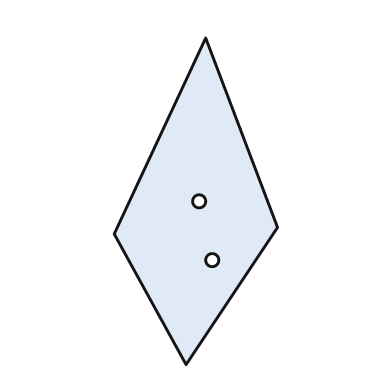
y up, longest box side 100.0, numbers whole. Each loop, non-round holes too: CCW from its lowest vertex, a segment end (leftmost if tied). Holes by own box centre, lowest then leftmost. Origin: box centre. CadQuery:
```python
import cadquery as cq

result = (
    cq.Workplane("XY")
    .moveTo(-3.0, -50.0)
    .lineTo(25.0, -8.0)
    .lineTo(3.0, 50.0)
    .lineTo(-25.0, -10.0)
    .close()
    .moveTo(5.0, -18.0)
    .circle(2.0)
    .moveTo(1.0, 0.0)
    .circle(2.0)
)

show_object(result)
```